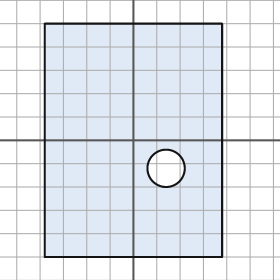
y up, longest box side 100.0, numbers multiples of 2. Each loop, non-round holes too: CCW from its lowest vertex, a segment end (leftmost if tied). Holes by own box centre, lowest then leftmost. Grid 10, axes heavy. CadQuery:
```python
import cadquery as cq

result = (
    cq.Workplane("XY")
    .moveTo(-38.0, -50.0)
    .lineTo(38.0, -50.0)
    .lineTo(38.0, 50.0)
    .lineTo(-38.0, 50.0)
    .close()
    .moveTo(14.0, -12.0)
    .circle(8.0)
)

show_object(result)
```